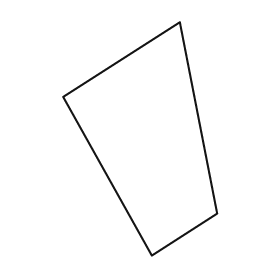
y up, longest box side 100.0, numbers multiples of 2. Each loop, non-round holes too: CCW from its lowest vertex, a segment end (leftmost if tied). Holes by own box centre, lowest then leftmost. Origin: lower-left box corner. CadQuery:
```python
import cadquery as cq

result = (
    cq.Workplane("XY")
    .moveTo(38.0, 0.0)
    .lineTo(66.0, 18.0)
    .lineTo(50.0, 100.0)
    .lineTo(0.0, 68.0)
    .close()
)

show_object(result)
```